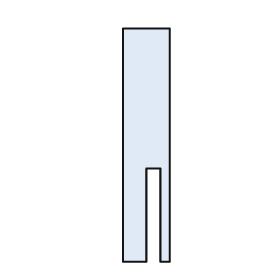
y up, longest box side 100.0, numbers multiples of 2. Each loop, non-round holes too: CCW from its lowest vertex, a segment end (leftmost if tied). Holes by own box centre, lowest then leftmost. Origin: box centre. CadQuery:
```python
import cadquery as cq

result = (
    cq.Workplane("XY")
    .moveTo(-10.0, -50.0)
    .lineTo(0.0, -50.0)
    .lineTo(0.0, -10.0)
    .lineTo(6.0, -10.0)
    .lineTo(6.0, -50.0)
    .lineTo(10.0, -50.0)
    .lineTo(10.0, 50.0)
    .lineTo(-10.0, 50.0)
    .close()
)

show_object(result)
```